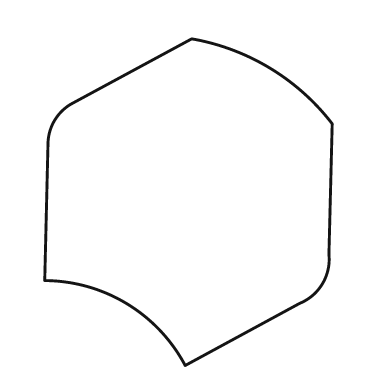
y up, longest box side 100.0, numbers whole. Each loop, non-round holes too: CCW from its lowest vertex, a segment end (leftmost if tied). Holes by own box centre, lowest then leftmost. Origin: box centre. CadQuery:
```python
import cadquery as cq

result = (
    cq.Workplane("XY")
    .moveTo(-1.0, -50.0)
    .lineTo(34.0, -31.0)
    .threePointArc((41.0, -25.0), (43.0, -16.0))
    .lineTo(44.0, 24.0)
    .threePointArc((25.0, 41.0), (1.0, 50.0))
    .lineTo(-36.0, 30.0)
    .threePointArc((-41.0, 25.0), (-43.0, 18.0))
    .lineTo(-44.0, -24.0)
    .threePointArc((-19.0, -31.0), (-1.0, -50.0))
    .close()
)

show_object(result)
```